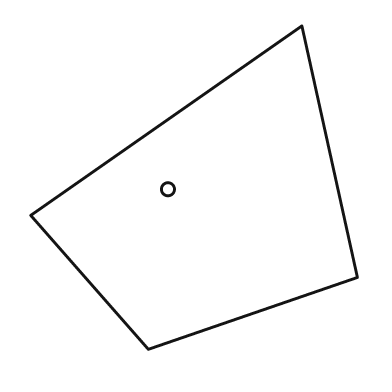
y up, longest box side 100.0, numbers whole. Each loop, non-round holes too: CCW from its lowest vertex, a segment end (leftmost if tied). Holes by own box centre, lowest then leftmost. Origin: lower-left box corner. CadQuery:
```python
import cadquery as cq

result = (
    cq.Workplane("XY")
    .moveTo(36.0, 0.0)
    .lineTo(100.0, 22.0)
    .lineTo(83.0, 99.0)
    .lineTo(0.0, 41.0)
    .close()
    .moveTo(42.0, 49.0)
    .circle(2.0)
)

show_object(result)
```